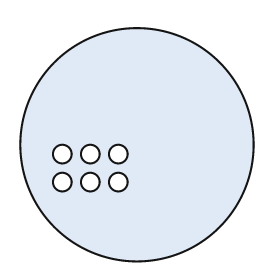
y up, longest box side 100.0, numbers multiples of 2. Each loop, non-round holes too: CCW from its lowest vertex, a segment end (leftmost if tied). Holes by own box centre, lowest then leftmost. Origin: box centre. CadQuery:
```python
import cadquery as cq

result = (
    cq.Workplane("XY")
    .moveTo(0.0, 0.0)
    .circle(50.0)
    .moveTo(-32.0, -16.0)
    .circle(4.0)
    .moveTo(-20.0, -16.0)
    .circle(4.0)
    .moveTo(-8.0, -16.0)
    .circle(4.0)
    .moveTo(-32.0, -4.0)
    .circle(4.0)
    .moveTo(-20.0, -4.0)
    .circle(4.0)
    .moveTo(-8.0, -4.0)
    .circle(4.0)
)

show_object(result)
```